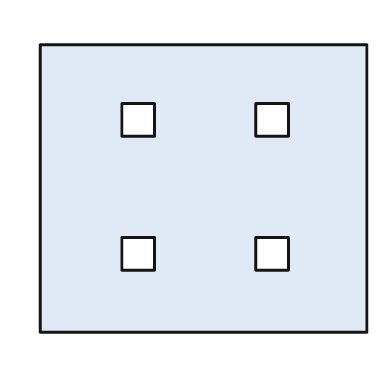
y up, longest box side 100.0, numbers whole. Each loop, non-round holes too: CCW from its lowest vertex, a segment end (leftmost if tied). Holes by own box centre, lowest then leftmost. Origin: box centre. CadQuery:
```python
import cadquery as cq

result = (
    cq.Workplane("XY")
    .moveTo(-50.0, -44.0)
    .lineTo(50.0, -44.0)
    .lineTo(50.0, 44.0)
    .lineTo(-50.0, 44.0)
    .close()
    .moveTo(-25.0, -25.0)
    .lineTo(-15.0, -25.0)
    .lineTo(-15.0, -15.0)
    .lineTo(-25.0, -15.0)
    .close()
    .moveTo(16.0, -25.0)
    .lineTo(26.0, -25.0)
    .lineTo(26.0, -15.0)
    .lineTo(16.0, -15.0)
    .close()
    .moveTo(-25.0, 16.0)
    .lineTo(-15.0, 16.0)
    .lineTo(-15.0, 26.0)
    .lineTo(-25.0, 26.0)
    .close()
    .moveTo(16.0, 16.0)
    .lineTo(26.0, 16.0)
    .lineTo(26.0, 26.0)
    .lineTo(16.0, 26.0)
    .close()
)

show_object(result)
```